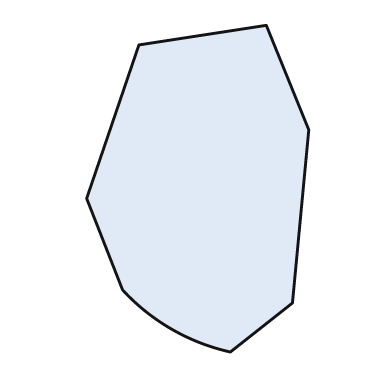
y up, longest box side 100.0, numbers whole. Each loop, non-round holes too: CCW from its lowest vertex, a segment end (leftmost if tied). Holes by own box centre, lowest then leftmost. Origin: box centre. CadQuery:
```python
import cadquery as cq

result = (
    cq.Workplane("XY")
    .moveTo(10.0, -50.0)
    .lineTo(29.0, -35.0)
    .lineTo(34.0, 18.0)
    .lineTo(21.0, 50.0)
    .lineTo(-18.0, 44.0)
    .lineTo(-34.0, -3.0)
    .lineTo(-23.0, -31.0)
    .threePointArc((-8.0, -43.0), (10.0, -50.0))
    .close()
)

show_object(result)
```